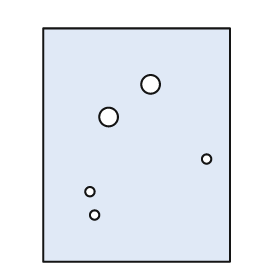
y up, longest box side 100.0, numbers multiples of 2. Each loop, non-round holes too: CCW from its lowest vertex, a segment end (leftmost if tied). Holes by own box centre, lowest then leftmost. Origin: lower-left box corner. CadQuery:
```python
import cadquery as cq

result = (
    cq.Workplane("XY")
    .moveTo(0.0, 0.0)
    .lineTo(80.0, 0.0)
    .lineTo(80.0, 100.0)
    .lineTo(0.0, 100.0)
    .close()
    .moveTo(22.0, 20.0)
    .circle(2.0)
    .moveTo(20.0, 30.0)
    .circle(2.0)
    .moveTo(70.0, 44.0)
    .circle(2.0)
    .moveTo(28.0, 62.0)
    .circle(4.0)
    .moveTo(46.0, 76.0)
    .circle(4.0)
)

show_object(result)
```